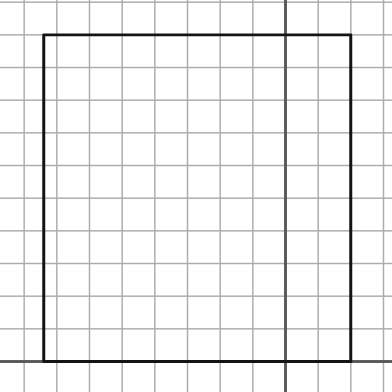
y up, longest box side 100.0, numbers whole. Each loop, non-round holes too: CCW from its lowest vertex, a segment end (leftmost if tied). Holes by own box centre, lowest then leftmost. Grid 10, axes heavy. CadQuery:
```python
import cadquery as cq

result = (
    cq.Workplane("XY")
    .moveTo(-74.0, 0.0)
    .lineTo(20.0, 0.0)
    .lineTo(20.0, 100.0)
    .lineTo(-74.0, 100.0)
    .close()
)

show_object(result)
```